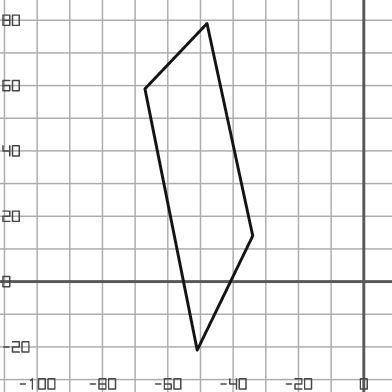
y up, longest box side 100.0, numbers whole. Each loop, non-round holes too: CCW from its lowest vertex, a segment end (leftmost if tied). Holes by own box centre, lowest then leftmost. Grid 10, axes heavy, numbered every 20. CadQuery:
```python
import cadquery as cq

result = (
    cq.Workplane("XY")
    .moveTo(-51.0, -21.0)
    .lineTo(-34.0, 14.0)
    .lineTo(-48.0, 79.0)
    .lineTo(-67.0, 59.0)
    .close()
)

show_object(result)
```